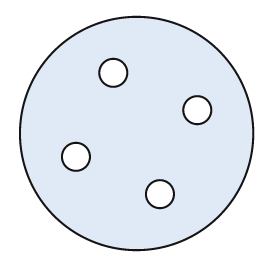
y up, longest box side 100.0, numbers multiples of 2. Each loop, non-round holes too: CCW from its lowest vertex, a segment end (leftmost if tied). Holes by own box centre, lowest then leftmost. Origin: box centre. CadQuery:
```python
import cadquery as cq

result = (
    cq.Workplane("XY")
    .moveTo(0.0, 0.0)
    .circle(50.0)
    .moveTo(10.0, -26.0)
    .circle(6.0)
    .moveTo(-26.0, -10.0)
    .circle(6.0)
    .moveTo(26.0, 10.0)
    .circle(6.0)
    .moveTo(-10.0, 26.0)
    .circle(6.0)
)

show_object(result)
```